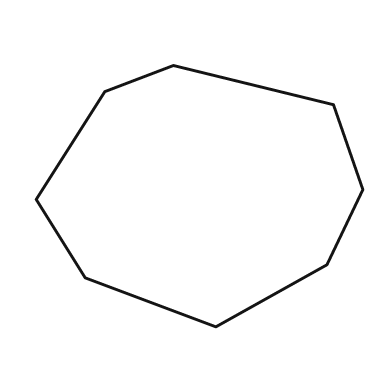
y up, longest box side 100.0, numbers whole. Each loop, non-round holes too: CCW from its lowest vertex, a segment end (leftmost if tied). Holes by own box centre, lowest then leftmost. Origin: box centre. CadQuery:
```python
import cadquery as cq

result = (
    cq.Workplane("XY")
    .moveTo(5.0, -40.0)
    .lineTo(39.0, -21.0)
    .lineTo(50.0, 2.0)
    .lineTo(41.0, 28.0)
    .lineTo(-8.0, 40.0)
    .lineTo(-29.0, 32.0)
    .lineTo(-50.0, -1.0)
    .lineTo(-35.0, -25.0)
    .close()
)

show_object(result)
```